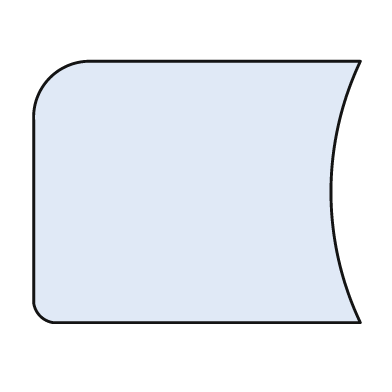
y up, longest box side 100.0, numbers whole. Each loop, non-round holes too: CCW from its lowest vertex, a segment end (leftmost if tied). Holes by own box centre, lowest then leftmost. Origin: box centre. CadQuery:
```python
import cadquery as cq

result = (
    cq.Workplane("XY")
    .moveTo(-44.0, -40.0)
    .lineTo(50.0, -40.0)
    .threePointArc((41.0, 0.0), (50.0, 40.0))
    .lineTo(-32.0, 40.0)
    .threePointArc((-45.0, 35.0), (-50.0, 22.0))
    .lineTo(-50.0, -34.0)
    .threePointArc((-48.0, -38.0), (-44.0, -40.0))
    .close()
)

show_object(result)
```